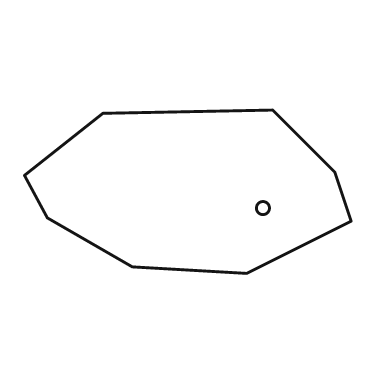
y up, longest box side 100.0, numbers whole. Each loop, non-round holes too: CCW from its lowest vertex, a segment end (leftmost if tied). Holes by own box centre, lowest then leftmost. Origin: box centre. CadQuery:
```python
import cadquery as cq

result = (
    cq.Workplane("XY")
    .moveTo(18.0, -25.0)
    .lineTo(50.0, -9.0)
    .lineTo(45.0, 6.0)
    .lineTo(26.0, 25.0)
    .lineTo(-26.0, 24.0)
    .lineTo(-50.0, 5.0)
    .lineTo(-43.0, -8.0)
    .lineTo(-17.0, -23.0)
    .close()
    .moveTo(23.0, -5.0)
    .circle(2.0)
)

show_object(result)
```